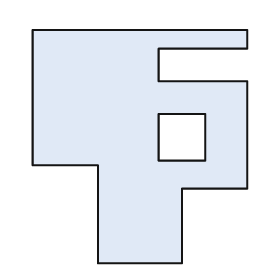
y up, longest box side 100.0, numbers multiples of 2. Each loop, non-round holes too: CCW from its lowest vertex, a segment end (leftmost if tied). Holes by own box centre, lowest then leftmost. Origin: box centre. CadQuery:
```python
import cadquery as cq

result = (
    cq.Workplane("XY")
    .moveTo(-18.0, -50.0)
    .lineTo(18.0, -50.0)
    .lineTo(18.0, -18.0)
    .lineTo(46.0, -18.0)
    .lineTo(46.0, 28.0)
    .lineTo(8.0, 28.0)
    .lineTo(8.0, 42.0)
    .lineTo(46.0, 42.0)
    .lineTo(46.0, 50.0)
    .lineTo(-46.0, 50.0)
    .lineTo(-46.0, -8.0)
    .lineTo(-18.0, -8.0)
    .close()
    .moveTo(8.0, -6.0)
    .lineTo(28.0, -6.0)
    .lineTo(28.0, 14.0)
    .lineTo(8.0, 14.0)
    .close()
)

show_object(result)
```